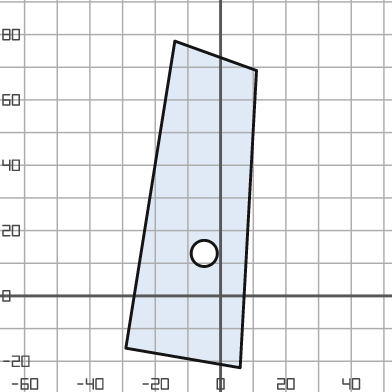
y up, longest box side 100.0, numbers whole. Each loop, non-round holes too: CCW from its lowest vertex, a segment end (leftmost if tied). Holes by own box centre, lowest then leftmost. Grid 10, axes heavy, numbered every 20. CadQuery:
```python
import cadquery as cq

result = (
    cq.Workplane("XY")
    .moveTo(6.0, -22.0)
    .lineTo(11.0, 69.0)
    .lineTo(-14.0, 78.0)
    .lineTo(-29.0, -16.0)
    .close()
    .moveTo(-5.0, 13.0)
    .circle(4.0)
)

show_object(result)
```